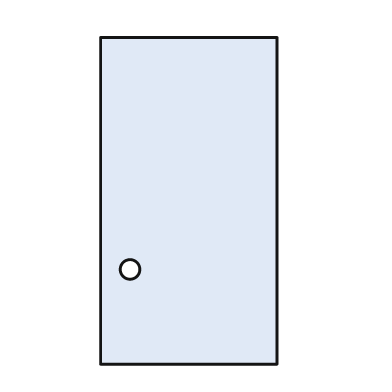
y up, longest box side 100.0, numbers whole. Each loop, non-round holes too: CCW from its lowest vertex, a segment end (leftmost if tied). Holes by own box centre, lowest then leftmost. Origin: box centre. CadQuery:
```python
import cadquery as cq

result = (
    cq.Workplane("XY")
    .moveTo(-27.0, -50.0)
    .lineTo(27.0, -50.0)
    .lineTo(27.0, 50.0)
    .lineTo(-27.0, 50.0)
    .close()
    .moveTo(-18.0, -21.0)
    .circle(3.0)
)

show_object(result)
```